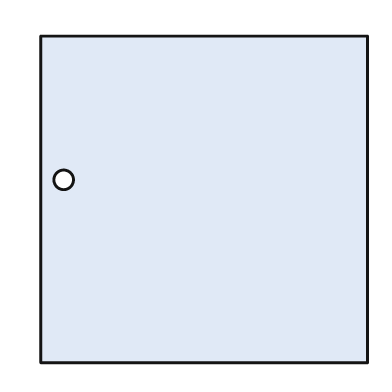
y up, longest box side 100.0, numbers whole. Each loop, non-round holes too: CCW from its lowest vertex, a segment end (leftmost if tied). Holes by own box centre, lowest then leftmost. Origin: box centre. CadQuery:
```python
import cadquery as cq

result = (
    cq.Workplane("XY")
    .moveTo(-50.0, -50.0)
    .lineTo(50.0, -50.0)
    .lineTo(50.0, 50.0)
    .lineTo(-50.0, 50.0)
    .close()
    .moveTo(-43.0, 6.0)
    .circle(3.0)
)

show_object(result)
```